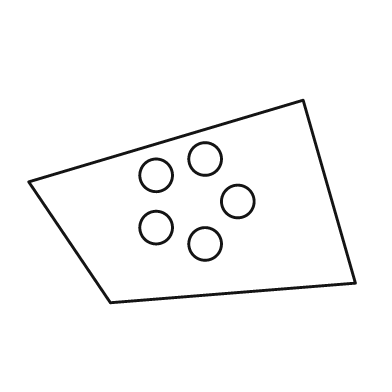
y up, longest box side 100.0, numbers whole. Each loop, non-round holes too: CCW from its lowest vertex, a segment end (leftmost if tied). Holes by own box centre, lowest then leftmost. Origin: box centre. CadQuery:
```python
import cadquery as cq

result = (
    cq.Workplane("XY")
    .moveTo(-25.0, -31.0)
    .lineTo(50.0, -25.0)
    .lineTo(34.0, 31.0)
    .lineTo(-50.0, 6.0)
    .close()
    .moveTo(4.0, -13.0)
    .circle(5.0)
    .moveTo(-11.0, -8.0)
    .circle(5.0)
    .moveTo(14.0, 0.0)
    .circle(5.0)
    .moveTo(-11.0, 8.0)
    .circle(5.0)
    .moveTo(4.0, 13.0)
    .circle(5.0)
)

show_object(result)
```